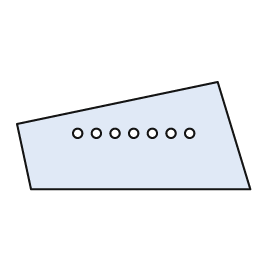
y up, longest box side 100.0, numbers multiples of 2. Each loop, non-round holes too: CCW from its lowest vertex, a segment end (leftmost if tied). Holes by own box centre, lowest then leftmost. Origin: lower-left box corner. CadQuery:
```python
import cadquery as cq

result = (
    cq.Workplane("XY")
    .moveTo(6.0, 0.0)
    .lineTo(100.0, 0.0)
    .lineTo(86.0, 46.0)
    .lineTo(0.0, 28.0)
    .close()
    .moveTo(26.0, 24.0)
    .circle(2.0)
    .moveTo(34.0, 24.0)
    .circle(2.0)
    .moveTo(42.0, 24.0)
    .circle(2.0)
    .moveTo(50.0, 24.0)
    .circle(2.0)
    .moveTo(58.0, 24.0)
    .circle(2.0)
    .moveTo(66.0, 24.0)
    .circle(2.0)
    .moveTo(74.0, 24.0)
    .circle(2.0)
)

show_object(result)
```